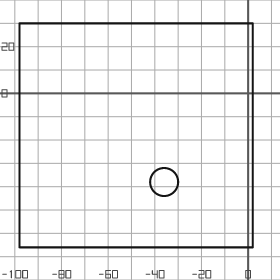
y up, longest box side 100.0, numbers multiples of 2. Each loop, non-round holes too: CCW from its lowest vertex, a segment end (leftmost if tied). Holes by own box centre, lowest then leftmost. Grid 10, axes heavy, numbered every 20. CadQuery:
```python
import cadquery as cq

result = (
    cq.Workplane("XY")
    .moveTo(-98.0, -66.0)
    .lineTo(2.0, -66.0)
    .lineTo(2.0, 30.0)
    .lineTo(-98.0, 30.0)
    .close()
    .moveTo(-36.0, -38.0)
    .circle(6.0)
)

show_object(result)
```